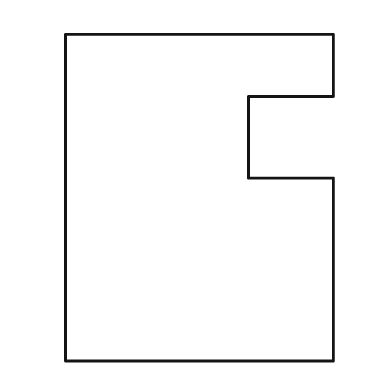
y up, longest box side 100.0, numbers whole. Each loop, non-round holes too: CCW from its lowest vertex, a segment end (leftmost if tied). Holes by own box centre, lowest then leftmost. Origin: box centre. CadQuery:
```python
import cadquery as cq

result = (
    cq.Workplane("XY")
    .moveTo(-41.0, -50.0)
    .lineTo(41.0, -50.0)
    .lineTo(41.0, 6.0)
    .lineTo(15.0, 6.0)
    .lineTo(15.0, 31.0)
    .lineTo(41.0, 31.0)
    .lineTo(41.0, 50.0)
    .lineTo(-41.0, 50.0)
    .close()
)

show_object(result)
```